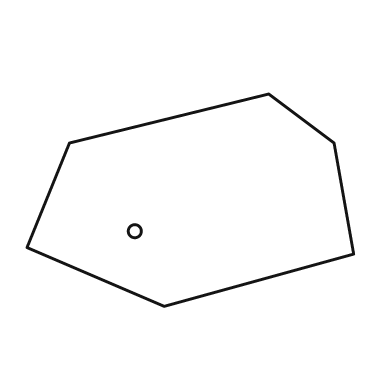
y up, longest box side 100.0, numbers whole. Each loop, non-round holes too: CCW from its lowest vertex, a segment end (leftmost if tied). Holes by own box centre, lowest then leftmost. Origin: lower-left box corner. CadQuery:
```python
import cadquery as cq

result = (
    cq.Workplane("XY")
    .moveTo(42.0, 0.0)
    .lineTo(100.0, 16.0)
    .lineTo(94.0, 50.0)
    .lineTo(74.0, 65.0)
    .lineTo(13.0, 50.0)
    .lineTo(0.0, 18.0)
    .close()
    .moveTo(33.0, 23.0)
    .circle(2.0)
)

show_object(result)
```